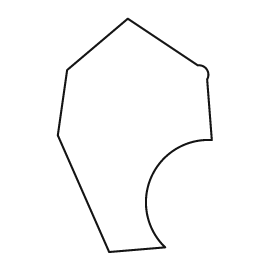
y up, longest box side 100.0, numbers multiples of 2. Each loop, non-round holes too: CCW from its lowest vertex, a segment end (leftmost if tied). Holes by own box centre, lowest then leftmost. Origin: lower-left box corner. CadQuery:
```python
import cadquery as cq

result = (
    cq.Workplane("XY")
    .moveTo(22.0, 0.0)
    .lineTo(46.0, 2.0)
    .threePointArc((40.0, 32.0), (66.0, 48.0))
    .lineTo(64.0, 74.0)
    .threePointArc((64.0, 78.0), (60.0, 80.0))
    .lineTo(30.0, 100.0)
    .lineTo(4.0, 78.0)
    .lineTo(0.0, 50.0)
    .close()
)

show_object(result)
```